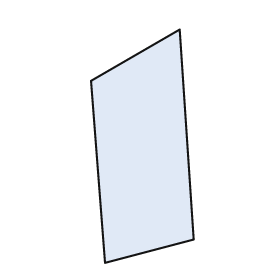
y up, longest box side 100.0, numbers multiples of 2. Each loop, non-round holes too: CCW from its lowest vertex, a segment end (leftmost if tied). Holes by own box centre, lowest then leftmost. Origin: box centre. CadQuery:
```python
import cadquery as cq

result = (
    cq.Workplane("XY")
    .moveTo(-16.0, -50.0)
    .lineTo(22.0, -40.0)
    .lineTo(16.0, 50.0)
    .lineTo(-22.0, 28.0)
    .close()
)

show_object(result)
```